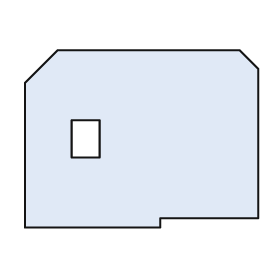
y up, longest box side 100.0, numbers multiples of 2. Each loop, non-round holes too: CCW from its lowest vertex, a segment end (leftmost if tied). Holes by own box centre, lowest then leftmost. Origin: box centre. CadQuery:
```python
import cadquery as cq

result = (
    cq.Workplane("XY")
    .moveTo(-50.0, -38.0)
    .lineTo(8.0, -38.0)
    .lineTo(8.0, -34.0)
    .lineTo(50.0, -34.0)
    .lineTo(50.0, 30.0)
    .lineTo(42.0, 38.0)
    .lineTo(-36.0, 38.0)
    .lineTo(-50.0, 24.0)
    .close()
    .moveTo(-30.0, -8.0)
    .lineTo(-18.0, -8.0)
    .lineTo(-18.0, 8.0)
    .lineTo(-30.0, 8.0)
    .close()
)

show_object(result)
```